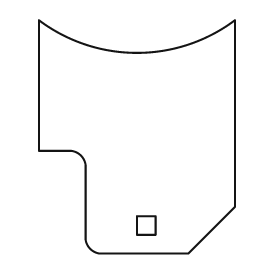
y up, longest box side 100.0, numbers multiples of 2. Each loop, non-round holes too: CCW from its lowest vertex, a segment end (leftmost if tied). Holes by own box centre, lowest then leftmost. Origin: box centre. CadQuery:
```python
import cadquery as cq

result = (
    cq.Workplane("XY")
    .moveTo(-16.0, -50.0)
    .lineTo(22.0, -50.0)
    .lineTo(42.0, -30.0)
    .lineTo(42.0, 50.0)
    .threePointArc((0.0, 36.0), (-42.0, 50.0))
    .lineTo(-42.0, -6.0)
    .lineTo(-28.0, -6.0)
    .threePointArc((-24.0, -8.0), (-22.0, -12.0))
    .lineTo(-22.0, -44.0)
    .threePointArc((-20.0, -48.0), (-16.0, -50.0))
    .close()
    .moveTo(0.0, -42.0)
    .lineTo(8.0, -42.0)
    .lineTo(8.0, -34.0)
    .lineTo(0.0, -34.0)
    .close()
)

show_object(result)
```